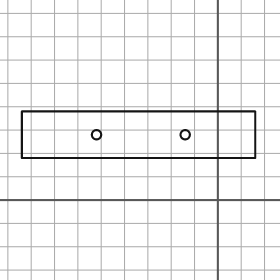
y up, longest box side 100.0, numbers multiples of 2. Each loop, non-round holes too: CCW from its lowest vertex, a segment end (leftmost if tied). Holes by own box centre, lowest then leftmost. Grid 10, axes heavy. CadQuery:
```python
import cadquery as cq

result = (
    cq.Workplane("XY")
    .moveTo(-84.0, 18.0)
    .lineTo(16.0, 18.0)
    .lineTo(16.0, 38.0)
    .lineTo(-84.0, 38.0)
    .close()
    .moveTo(-52.0, 28.0)
    .circle(2.0)
    .moveTo(-14.0, 28.0)
    .circle(2.0)
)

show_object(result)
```